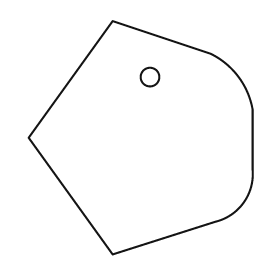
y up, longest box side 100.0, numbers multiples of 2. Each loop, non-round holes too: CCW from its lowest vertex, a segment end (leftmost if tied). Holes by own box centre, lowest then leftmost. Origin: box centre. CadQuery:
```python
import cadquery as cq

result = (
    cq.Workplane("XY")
    .moveTo(-12.0, -50.0)
    .lineTo(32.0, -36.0)
    .threePointArc((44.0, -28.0), (48.0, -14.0))
    .lineTo(48.0, 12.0)
    .threePointArc((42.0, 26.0), (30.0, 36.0))
    .lineTo(-12.0, 50.0)
    .lineTo(-48.0, 0.0)
    .close()
    .moveTo(4.0, 26.0)
    .circle(4.0)
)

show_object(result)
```